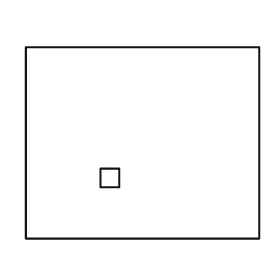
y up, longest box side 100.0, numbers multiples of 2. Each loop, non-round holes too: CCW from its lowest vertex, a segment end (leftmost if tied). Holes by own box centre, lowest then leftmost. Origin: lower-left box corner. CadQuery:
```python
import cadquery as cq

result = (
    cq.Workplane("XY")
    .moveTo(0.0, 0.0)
    .lineTo(100.0, 0.0)
    .lineTo(100.0, 82.0)
    .lineTo(0.0, 82.0)
    .close()
    .moveTo(32.0, 22.0)
    .lineTo(40.0, 22.0)
    .lineTo(40.0, 30.0)
    .lineTo(32.0, 30.0)
    .close()
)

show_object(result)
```